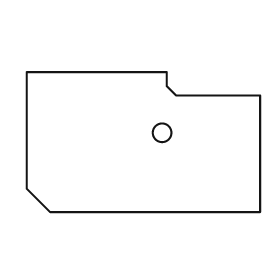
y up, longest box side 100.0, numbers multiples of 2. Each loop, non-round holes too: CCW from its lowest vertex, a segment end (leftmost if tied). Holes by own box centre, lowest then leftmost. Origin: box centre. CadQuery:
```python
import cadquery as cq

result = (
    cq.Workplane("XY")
    .moveTo(-40.0, -30.0)
    .lineTo(50.0, -30.0)
    .lineTo(50.0, 20.0)
    .lineTo(14.0, 20.0)
    .lineTo(10.0, 24.0)
    .lineTo(10.0, 30.0)
    .lineTo(-50.0, 30.0)
    .lineTo(-50.0, -20.0)
    .close()
    .moveTo(8.0, 4.0)
    .circle(4.0)
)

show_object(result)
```